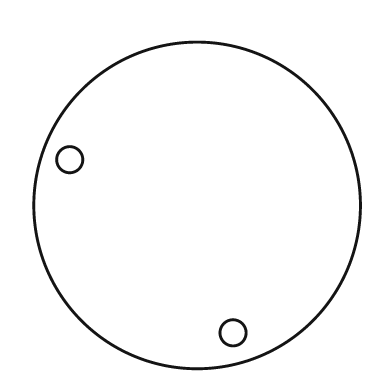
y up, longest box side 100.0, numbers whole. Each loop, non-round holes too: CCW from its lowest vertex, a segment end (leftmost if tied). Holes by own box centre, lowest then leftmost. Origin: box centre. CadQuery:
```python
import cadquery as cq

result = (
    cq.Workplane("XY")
    .moveTo(0.0, 0.0)
    .circle(50.0)
    .moveTo(11.0, -39.0)
    .circle(4.0)
    .moveTo(-39.0, 14.0)
    .circle(4.0)
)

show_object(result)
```